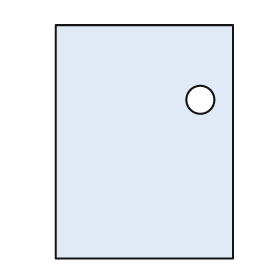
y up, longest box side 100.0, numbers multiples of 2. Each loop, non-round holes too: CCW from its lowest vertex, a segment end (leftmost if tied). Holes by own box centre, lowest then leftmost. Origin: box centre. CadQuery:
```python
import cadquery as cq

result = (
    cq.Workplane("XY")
    .moveTo(-38.0, -50.0)
    .lineTo(38.0, -50.0)
    .lineTo(38.0, 50.0)
    .lineTo(-38.0, 50.0)
    .close()
    .moveTo(24.0, 18.0)
    .circle(6.0)
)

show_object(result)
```